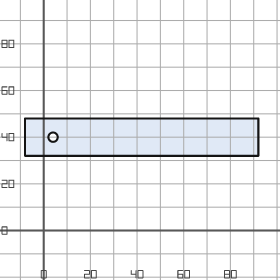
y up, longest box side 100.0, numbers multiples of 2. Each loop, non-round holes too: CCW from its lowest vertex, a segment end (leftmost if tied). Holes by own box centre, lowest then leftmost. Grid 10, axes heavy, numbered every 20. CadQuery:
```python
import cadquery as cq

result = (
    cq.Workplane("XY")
    .moveTo(-8.0, 32.0)
    .lineTo(92.0, 32.0)
    .lineTo(92.0, 48.0)
    .lineTo(-8.0, 48.0)
    .close()
    .moveTo(4.0, 40.0)
    .circle(2.0)
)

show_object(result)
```